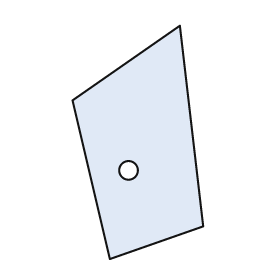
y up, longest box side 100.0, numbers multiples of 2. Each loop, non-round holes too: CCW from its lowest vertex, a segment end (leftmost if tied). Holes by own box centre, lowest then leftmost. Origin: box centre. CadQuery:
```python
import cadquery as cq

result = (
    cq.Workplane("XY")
    .moveTo(-12.0, -50.0)
    .lineTo(28.0, -36.0)
    .lineTo(18.0, 50.0)
    .lineTo(-28.0, 18.0)
    .close()
    .moveTo(-4.0, -12.0)
    .circle(4.0)
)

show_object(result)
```